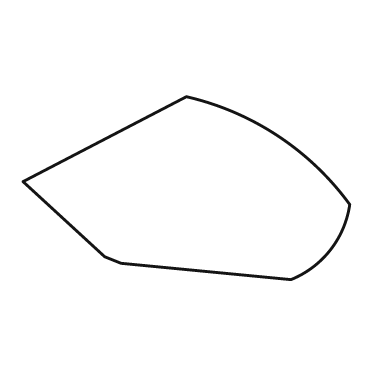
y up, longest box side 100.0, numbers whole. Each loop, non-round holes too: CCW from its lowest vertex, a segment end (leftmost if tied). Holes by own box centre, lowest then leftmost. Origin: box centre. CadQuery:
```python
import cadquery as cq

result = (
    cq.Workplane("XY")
    .moveTo(32.0, -28.0)
    .threePointArc((44.0, -19.0), (50.0, -5.0))
    .threePointArc((28.0, 16.0), (0.0, 28.0))
    .lineTo(-50.0, 2.0)
    .lineTo(-25.0, -21.0)
    .lineTo(-20.0, -23.0)
    .close()
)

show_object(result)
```